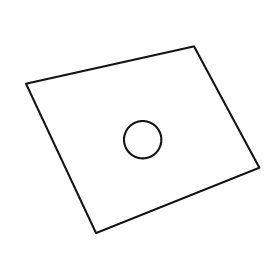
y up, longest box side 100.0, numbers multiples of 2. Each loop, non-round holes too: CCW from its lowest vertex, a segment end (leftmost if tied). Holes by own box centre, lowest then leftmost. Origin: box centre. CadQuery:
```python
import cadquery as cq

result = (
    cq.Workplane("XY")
    .moveTo(-20.0, -40.0)
    .lineTo(50.0, -12.0)
    .lineTo(22.0, 40.0)
    .lineTo(-50.0, 24.0)
    .close()
    .moveTo(0.0, 0.0)
    .circle(8.0)
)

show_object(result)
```